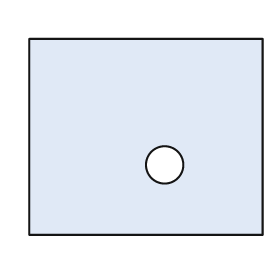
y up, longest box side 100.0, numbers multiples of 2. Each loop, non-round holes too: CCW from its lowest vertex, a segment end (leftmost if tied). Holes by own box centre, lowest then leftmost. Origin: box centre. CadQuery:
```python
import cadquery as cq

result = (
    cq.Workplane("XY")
    .moveTo(-50.0, -42.0)
    .lineTo(50.0, -42.0)
    .lineTo(50.0, 42.0)
    .lineTo(-50.0, 42.0)
    .close()
    .moveTo(8.0, -12.0)
    .circle(8.0)
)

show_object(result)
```